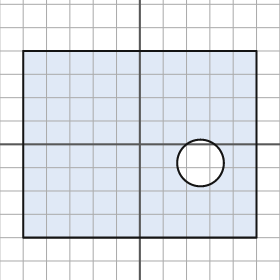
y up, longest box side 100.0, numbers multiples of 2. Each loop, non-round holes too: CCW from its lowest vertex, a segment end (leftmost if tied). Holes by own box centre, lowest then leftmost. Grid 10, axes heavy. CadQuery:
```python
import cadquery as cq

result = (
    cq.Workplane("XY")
    .moveTo(-50.0, -40.0)
    .lineTo(50.0, -40.0)
    .lineTo(50.0, 40.0)
    .lineTo(-50.0, 40.0)
    .close()
    .moveTo(26.0, -8.0)
    .circle(10.0)
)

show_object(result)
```